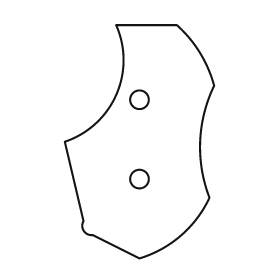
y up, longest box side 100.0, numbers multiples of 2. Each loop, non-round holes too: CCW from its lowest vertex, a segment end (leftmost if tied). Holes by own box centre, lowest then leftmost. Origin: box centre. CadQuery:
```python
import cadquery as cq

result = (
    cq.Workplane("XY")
    .moveTo(0.0, -50.0)
    .threePointArc((18.0, -40.0), (30.0, -24.0))
    .threePointArc((26.0, 0.0), (32.0, 24.0))
    .threePointArc((26.0, 38.0), (16.0, 50.0))
    .lineTo(-10.0, 50.0)
    .threePointArc((-10.0, 20.0), (-32.0, 0.0))
    .lineTo(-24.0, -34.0)
    .threePointArc((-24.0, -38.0), (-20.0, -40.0))
    .close()
    .moveTo(0.0, -16.0)
    .circle(4.0)
    .moveTo(0.0, 18.0)
    .circle(4.0)
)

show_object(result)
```